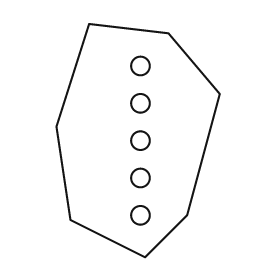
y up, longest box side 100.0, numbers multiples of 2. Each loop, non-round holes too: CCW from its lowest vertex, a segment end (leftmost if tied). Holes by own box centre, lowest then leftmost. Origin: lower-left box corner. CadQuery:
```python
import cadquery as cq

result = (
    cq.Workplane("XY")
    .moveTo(38.0, 0.0)
    .lineTo(56.0, 18.0)
    .lineTo(70.0, 70.0)
    .lineTo(48.0, 96.0)
    .lineTo(14.0, 100.0)
    .lineTo(0.0, 56.0)
    .lineTo(6.0, 16.0)
    .close()
    .moveTo(36.0, 18.0)
    .circle(4.0)
    .moveTo(36.0, 34.0)
    .circle(4.0)
    .moveTo(36.0, 50.0)
    .circle(4.0)
    .moveTo(36.0, 66.0)
    .circle(4.0)
    .moveTo(36.0, 82.0)
    .circle(4.0)
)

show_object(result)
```